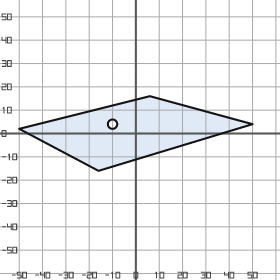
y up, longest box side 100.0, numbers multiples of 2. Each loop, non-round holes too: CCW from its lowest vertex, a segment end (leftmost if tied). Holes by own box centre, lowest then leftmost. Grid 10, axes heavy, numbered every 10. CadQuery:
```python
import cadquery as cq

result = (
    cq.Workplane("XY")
    .moveTo(-16.0, -16.0)
    .lineTo(50.0, 4.0)
    .lineTo(6.0, 16.0)
    .lineTo(-50.0, 2.0)
    .close()
    .moveTo(-10.0, 4.0)
    .circle(2.0)
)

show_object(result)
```